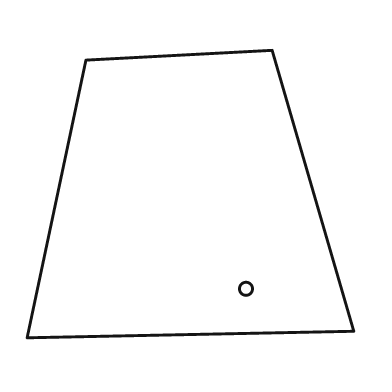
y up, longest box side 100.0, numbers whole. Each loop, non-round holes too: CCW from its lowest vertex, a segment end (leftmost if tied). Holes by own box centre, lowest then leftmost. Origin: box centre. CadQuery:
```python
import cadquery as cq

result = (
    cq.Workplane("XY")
    .moveTo(-50.0, -44.0)
    .lineTo(50.0, -42.0)
    .lineTo(25.0, 44.0)
    .lineTo(-32.0, 41.0)
    .close()
    .moveTo(17.0, -29.0)
    .circle(2.0)
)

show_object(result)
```